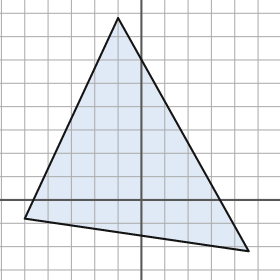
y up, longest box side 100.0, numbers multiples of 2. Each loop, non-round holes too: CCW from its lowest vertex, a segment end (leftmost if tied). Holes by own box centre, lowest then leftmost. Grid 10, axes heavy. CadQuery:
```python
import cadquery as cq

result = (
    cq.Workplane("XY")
    .moveTo(46.0, -22.0)
    .lineTo(-10.0, 78.0)
    .lineTo(-50.0, -8.0)
    .close()
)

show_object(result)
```